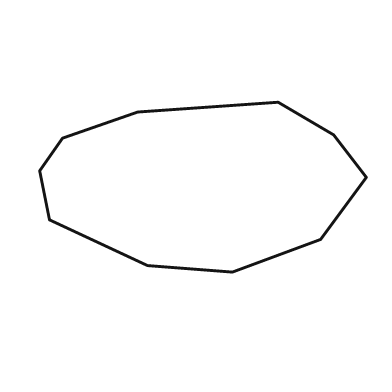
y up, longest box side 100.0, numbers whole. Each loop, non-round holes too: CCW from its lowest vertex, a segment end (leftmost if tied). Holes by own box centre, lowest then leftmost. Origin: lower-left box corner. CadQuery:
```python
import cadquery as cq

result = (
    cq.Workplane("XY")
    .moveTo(59.0, 0.0)
    .lineTo(86.0, 10.0)
    .lineTo(100.0, 29.0)
    .lineTo(90.0, 42.0)
    .lineTo(73.0, 52.0)
    .lineTo(30.0, 49.0)
    .lineTo(7.0, 41.0)
    .lineTo(0.0, 31.0)
    .lineTo(3.0, 16.0)
    .lineTo(33.0, 2.0)
    .close()
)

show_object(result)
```